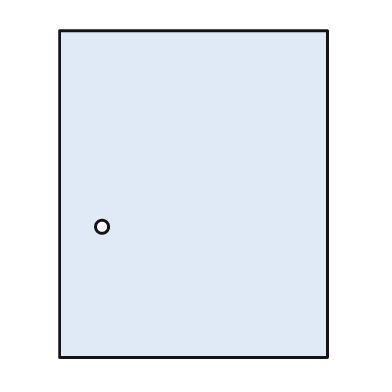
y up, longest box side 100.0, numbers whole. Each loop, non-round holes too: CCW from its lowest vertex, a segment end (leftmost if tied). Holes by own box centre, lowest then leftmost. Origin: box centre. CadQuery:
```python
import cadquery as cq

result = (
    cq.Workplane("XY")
    .moveTo(-41.0, -50.0)
    .lineTo(41.0, -50.0)
    .lineTo(41.0, 50.0)
    .lineTo(-41.0, 50.0)
    .close()
    .moveTo(-28.0, -10.0)
    .circle(2.0)
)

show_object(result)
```